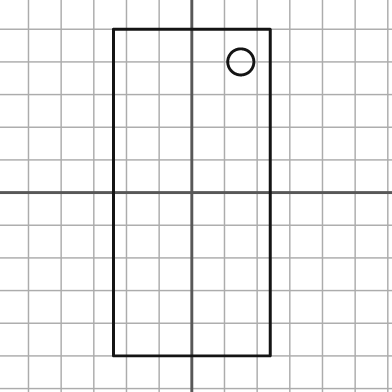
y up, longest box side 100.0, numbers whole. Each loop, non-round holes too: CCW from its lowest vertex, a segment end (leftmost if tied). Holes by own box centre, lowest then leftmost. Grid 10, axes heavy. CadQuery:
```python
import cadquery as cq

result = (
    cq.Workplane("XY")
    .moveTo(-24.0, -50.0)
    .lineTo(24.0, -50.0)
    .lineTo(24.0, 50.0)
    .lineTo(-24.0, 50.0)
    .close()
    .moveTo(15.0, 40.0)
    .circle(4.0)
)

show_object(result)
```